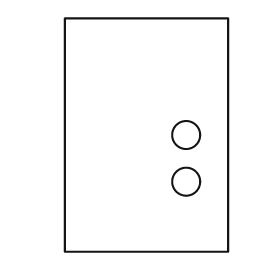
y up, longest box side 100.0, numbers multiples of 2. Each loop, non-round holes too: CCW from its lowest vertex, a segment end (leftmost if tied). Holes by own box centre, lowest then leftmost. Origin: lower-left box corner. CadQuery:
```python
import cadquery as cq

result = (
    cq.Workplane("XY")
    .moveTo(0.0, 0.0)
    .lineTo(70.0, 0.0)
    .lineTo(70.0, 100.0)
    .lineTo(0.0, 100.0)
    .close()
    .moveTo(52.0, 30.0)
    .circle(6.0)
    .moveTo(52.0, 50.0)
    .circle(6.0)
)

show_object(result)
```